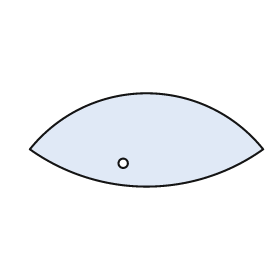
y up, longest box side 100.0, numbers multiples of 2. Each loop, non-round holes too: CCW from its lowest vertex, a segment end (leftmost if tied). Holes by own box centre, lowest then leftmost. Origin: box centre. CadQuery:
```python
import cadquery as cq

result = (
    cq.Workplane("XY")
    .moveTo(-50.0, -4.0)
    .threePointArc((0.0, -20.0), (50.0, -4.0))
    .threePointArc((0.0, 20.0), (-50.0, -4.0))
    .close()
    .moveTo(-10.0, -10.0)
    .circle(2.0)
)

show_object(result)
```